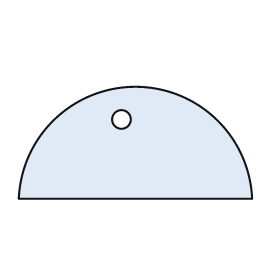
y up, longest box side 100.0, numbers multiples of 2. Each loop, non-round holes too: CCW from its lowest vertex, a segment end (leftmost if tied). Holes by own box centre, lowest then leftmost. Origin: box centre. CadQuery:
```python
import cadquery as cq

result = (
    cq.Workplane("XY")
    .moveTo(-50.0, -24.0)
    .lineTo(50.0, -24.0)
    .threePointArc((0.0, 24.0), (-50.0, -24.0))
    .close()
    .moveTo(-6.0, 10.0)
    .circle(4.0)
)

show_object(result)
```